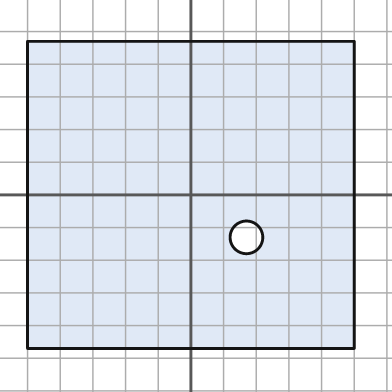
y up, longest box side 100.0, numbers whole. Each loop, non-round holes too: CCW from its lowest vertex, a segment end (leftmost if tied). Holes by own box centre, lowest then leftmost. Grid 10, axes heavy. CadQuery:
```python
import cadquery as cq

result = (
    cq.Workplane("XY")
    .moveTo(-50.0, -47.0)
    .lineTo(50.0, -47.0)
    .lineTo(50.0, 47.0)
    .lineTo(-50.0, 47.0)
    .close()
    .moveTo(17.0, -13.0)
    .circle(5.0)
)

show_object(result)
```